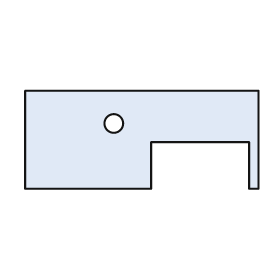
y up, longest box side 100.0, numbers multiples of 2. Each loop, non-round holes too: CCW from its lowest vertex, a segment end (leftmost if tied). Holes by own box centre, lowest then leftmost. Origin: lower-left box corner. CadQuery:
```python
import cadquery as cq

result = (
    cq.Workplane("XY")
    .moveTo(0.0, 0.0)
    .lineTo(54.0, 0.0)
    .lineTo(54.0, 20.0)
    .lineTo(96.0, 20.0)
    .lineTo(96.0, 0.0)
    .lineTo(100.0, 0.0)
    .lineTo(100.0, 42.0)
    .lineTo(0.0, 42.0)
    .close()
    .moveTo(38.0, 28.0)
    .circle(4.0)
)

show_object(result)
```